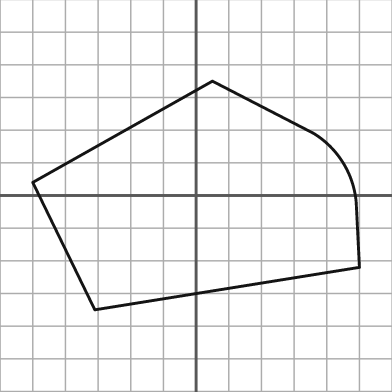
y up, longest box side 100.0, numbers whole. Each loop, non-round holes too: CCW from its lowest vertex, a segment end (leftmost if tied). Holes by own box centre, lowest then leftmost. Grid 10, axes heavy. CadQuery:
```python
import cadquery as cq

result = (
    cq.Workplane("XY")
    .moveTo(-31.0, -35.0)
    .lineTo(50.0, -22.0)
    .lineTo(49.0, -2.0)
    .threePointArc((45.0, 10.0), (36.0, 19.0))
    .lineTo(5.0, 35.0)
    .lineTo(-50.0, 4.0)
    .close()
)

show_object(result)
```